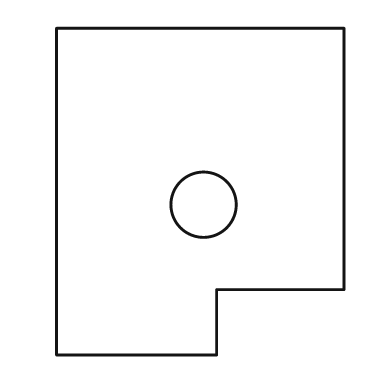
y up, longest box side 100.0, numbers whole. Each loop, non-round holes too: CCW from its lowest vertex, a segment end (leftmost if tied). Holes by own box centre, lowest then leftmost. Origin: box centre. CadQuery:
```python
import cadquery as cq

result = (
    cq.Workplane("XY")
    .moveTo(-44.0, -50.0)
    .lineTo(5.0, -50.0)
    .lineTo(5.0, -30.0)
    .lineTo(44.0, -30.0)
    .lineTo(44.0, 50.0)
    .lineTo(-44.0, 50.0)
    .close()
    .moveTo(1.0, -4.0)
    .circle(10.0)
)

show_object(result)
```